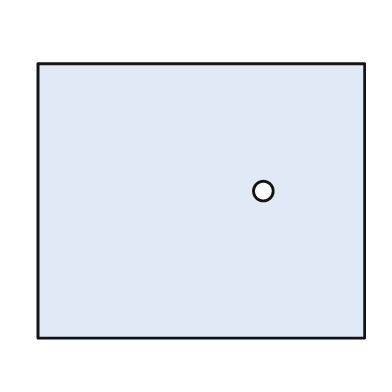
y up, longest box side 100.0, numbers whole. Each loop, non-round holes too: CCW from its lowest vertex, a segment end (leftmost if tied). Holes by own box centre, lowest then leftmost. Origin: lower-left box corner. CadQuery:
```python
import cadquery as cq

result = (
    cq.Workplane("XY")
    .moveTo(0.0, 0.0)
    .lineTo(100.0, 0.0)
    .lineTo(100.0, 84.0)
    .lineTo(0.0, 84.0)
    .close()
    .moveTo(69.0, 45.0)
    .circle(3.0)
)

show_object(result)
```